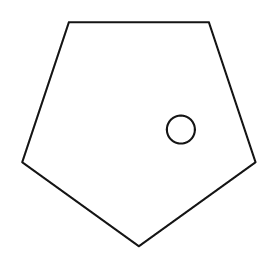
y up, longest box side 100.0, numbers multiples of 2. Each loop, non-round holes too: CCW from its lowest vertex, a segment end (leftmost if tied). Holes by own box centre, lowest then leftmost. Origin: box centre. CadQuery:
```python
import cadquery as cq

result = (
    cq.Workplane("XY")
    .moveTo(0.0, -48.0)
    .lineTo(50.0, -12.0)
    .lineTo(30.0, 48.0)
    .lineTo(-30.0, 48.0)
    .lineTo(-50.0, -12.0)
    .close()
    .moveTo(18.0, 2.0)
    .circle(6.0)
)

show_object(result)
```